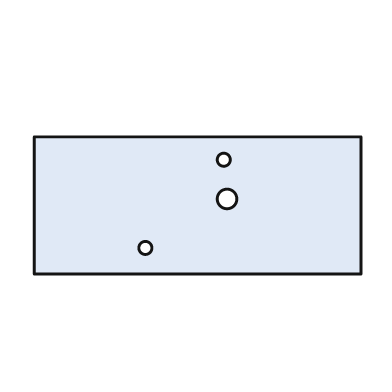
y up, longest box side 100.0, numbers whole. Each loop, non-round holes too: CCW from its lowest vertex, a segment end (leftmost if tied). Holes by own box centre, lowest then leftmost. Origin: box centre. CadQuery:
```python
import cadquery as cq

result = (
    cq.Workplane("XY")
    .moveTo(-50.0, -21.0)
    .lineTo(50.0, -21.0)
    .lineTo(50.0, 21.0)
    .lineTo(-50.0, 21.0)
    .close()
    .moveTo(-16.0, -13.0)
    .circle(2.0)
    .moveTo(9.0, 2.0)
    .circle(3.0)
    .moveTo(8.0, 14.0)
    .circle(2.0)
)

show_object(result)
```